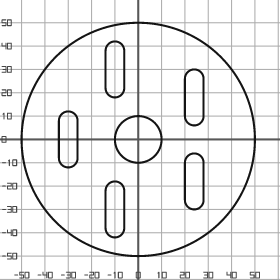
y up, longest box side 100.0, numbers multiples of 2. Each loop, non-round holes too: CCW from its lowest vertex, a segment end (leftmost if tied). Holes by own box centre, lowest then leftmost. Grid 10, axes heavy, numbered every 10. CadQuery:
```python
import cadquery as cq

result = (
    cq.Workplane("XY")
    .moveTo(0.0, 0.0)
    .circle(50.0)
    .moveTo(-14.0, -38.0)
    .threePointArc((-10.0, -42.0), (-6.0, -38.0))
    .lineTo(-6.0, -22.0)
    .threePointArc((-10.0, -18.0), (-14.0, -22.0))
    .close()
    .moveTo(20.0, -26.0)
    .threePointArc((24.0, -30.0), (28.0, -26.0))
    .lineTo(28.0, -10.0)
    .threePointArc((24.0, -6.0), (20.0, -10.0))
    .close()
    .moveTo(-34.0, -8.0)
    .threePointArc((-30.0, -12.0), (-26.0, -8.0))
    .lineTo(-26.0, 8.0)
    .threePointArc((-30.0, 12.0), (-34.0, 8.0))
    .close()
    .moveTo(0.0, 0.0)
    .circle(10.0)
    .moveTo(20.0, 10.0)
    .threePointArc((24.0, 6.0), (28.0, 10.0))
    .lineTo(28.0, 26.0)
    .threePointArc((24.0, 30.0), (20.0, 26.0))
    .close()
    .moveTo(-14.0, 22.0)
    .threePointArc((-10.0, 18.0), (-6.0, 22.0))
    .lineTo(-6.0, 38.0)
    .threePointArc((-10.0, 42.0), (-14.0, 38.0))
    .close()
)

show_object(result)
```